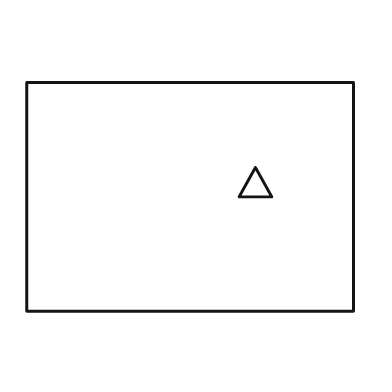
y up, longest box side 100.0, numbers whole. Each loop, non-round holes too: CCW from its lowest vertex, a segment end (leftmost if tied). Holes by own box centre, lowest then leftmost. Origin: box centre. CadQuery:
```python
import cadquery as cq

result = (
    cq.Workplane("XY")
    .moveTo(-50.0, -35.0)
    .lineTo(50.0, -35.0)
    .lineTo(50.0, 35.0)
    .lineTo(-50.0, 35.0)
    .close()
    .moveTo(15.0, 0.0)
    .lineTo(25.0, 0.0)
    .lineTo(20.0, 9.0)
    .close()
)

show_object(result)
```